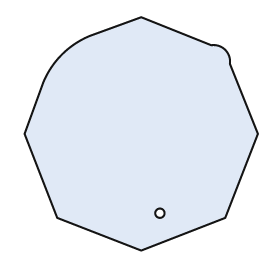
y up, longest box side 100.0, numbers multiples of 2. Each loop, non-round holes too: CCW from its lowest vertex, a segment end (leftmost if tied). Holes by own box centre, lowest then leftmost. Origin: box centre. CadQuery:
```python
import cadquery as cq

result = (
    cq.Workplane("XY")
    .moveTo(0.0, -50.0)
    .lineTo(36.0, -36.0)
    .lineTo(50.0, 0.0)
    .lineTo(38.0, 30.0)
    .threePointArc((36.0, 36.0), (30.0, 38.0))
    .lineTo(0.0, 50.0)
    .lineTo(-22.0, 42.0)
    .threePointArc((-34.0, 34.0), (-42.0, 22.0))
    .lineTo(-50.0, 0.0)
    .lineTo(-36.0, -36.0)
    .close()
    .moveTo(8.0, -34.0)
    .circle(2.0)
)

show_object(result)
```